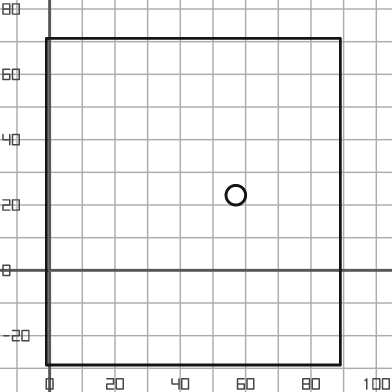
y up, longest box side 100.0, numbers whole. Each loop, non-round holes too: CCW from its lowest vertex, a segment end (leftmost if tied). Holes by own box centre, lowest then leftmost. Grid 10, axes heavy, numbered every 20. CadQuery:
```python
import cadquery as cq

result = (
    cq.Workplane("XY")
    .moveTo(-1.0, -29.0)
    .lineTo(89.0, -29.0)
    .lineTo(89.0, 71.0)
    .lineTo(-1.0, 71.0)
    .close()
    .moveTo(57.0, 23.0)
    .circle(3.0)
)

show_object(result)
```